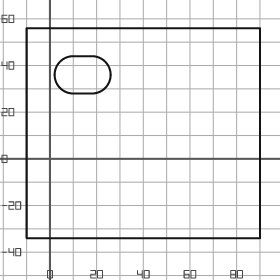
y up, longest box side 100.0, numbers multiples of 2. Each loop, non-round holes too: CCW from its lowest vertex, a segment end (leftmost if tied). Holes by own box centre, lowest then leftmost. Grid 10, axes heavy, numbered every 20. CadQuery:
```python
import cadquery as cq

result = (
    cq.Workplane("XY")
    .moveTo(-10.0, -34.0)
    .lineTo(90.0, -34.0)
    .lineTo(90.0, 56.0)
    .lineTo(-10.0, 56.0)
    .close()
    .moveTo(10.0, 28.0)
    .lineTo(18.0, 28.0)
    .threePointArc((26.0, 36.0), (18.0, 44.0))
    .lineTo(10.0, 44.0)
    .threePointArc((2.0, 36.0), (10.0, 28.0))
    .close()
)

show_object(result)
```